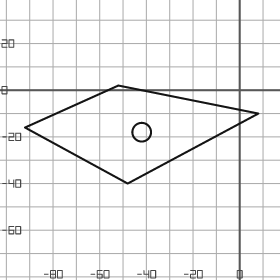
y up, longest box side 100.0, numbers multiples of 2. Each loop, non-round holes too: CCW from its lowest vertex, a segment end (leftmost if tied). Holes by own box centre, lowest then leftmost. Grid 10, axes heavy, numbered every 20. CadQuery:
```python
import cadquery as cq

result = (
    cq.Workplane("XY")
    .moveTo(-48.0, -40.0)
    .lineTo(8.0, -10.0)
    .lineTo(-52.0, 2.0)
    .lineTo(-92.0, -16.0)
    .close()
    .moveTo(-42.0, -18.0)
    .circle(4.0)
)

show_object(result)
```